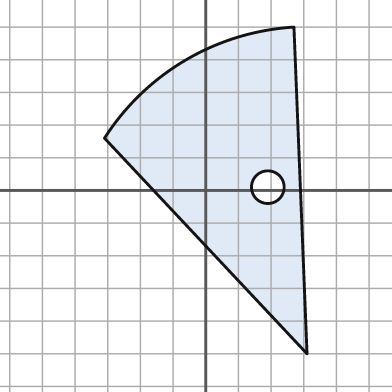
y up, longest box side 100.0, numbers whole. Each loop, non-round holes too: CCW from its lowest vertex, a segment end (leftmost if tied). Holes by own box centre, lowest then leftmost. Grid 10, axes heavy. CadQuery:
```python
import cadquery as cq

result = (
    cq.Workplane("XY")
    .moveTo(31.0, -50.0)
    .lineTo(27.0, 50.0)
    .threePointArc((-6.0, 40.0), (-31.0, 16.0))
    .close()
    .moveTo(19.0, 1.0)
    .circle(5.0)
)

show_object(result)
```